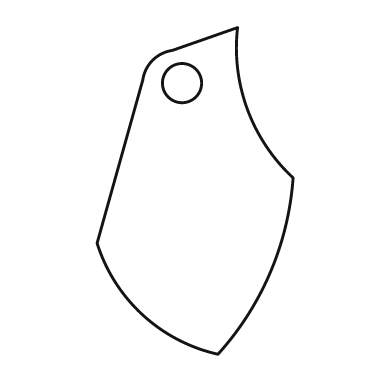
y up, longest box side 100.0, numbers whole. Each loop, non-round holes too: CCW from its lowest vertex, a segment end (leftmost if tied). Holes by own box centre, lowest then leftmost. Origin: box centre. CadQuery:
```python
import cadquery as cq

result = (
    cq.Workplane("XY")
    .moveTo(7.0, -50.0)
    .threePointArc((23.0, -25.0), (30.0, 4.0))
    .threePointArc((16.0, 25.0), (13.0, 50.0))
    .lineTo(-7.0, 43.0)
    .threePointArc((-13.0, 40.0), (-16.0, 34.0))
    .lineTo(-30.0, -16.0)
    .threePointArc((-16.0, -38.0), (7.0, -50.0))
    .close()
    .moveTo(-4.0, 33.0)
    .circle(6.0)
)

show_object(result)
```